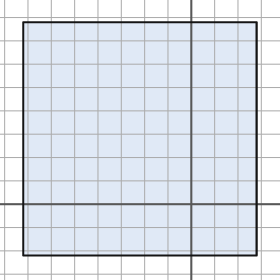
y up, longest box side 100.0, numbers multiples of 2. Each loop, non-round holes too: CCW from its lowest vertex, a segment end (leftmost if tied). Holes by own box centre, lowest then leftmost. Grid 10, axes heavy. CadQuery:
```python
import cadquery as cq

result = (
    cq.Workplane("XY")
    .moveTo(-72.0, -22.0)
    .lineTo(28.0, -22.0)
    .lineTo(28.0, 78.0)
    .lineTo(-72.0, 78.0)
    .close()
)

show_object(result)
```